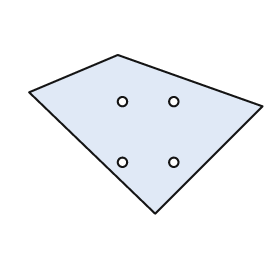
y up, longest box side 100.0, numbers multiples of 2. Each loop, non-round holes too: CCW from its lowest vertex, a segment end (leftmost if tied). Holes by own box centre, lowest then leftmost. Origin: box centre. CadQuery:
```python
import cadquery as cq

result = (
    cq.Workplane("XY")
    .moveTo(4.0, -34.0)
    .lineTo(50.0, 12.0)
    .lineTo(-12.0, 34.0)
    .lineTo(-50.0, 18.0)
    .close()
    .moveTo(-10.0, -12.0)
    .circle(2.0)
    .moveTo(12.0, -12.0)
    .circle(2.0)
    .moveTo(-10.0, 14.0)
    .circle(2.0)
    .moveTo(12.0, 14.0)
    .circle(2.0)
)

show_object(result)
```